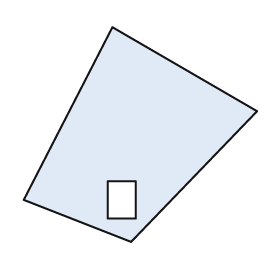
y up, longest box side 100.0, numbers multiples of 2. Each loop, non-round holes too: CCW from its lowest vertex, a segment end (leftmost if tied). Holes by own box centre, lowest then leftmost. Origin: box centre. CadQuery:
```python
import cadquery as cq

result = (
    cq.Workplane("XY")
    .moveTo(-4.0, -46.0)
    .lineTo(50.0, 10.0)
    .lineTo(-12.0, 46.0)
    .lineTo(-50.0, -28.0)
    .close()
    .moveTo(-14.0, -36.0)
    .lineTo(-2.0, -36.0)
    .lineTo(-2.0, -20.0)
    .lineTo(-14.0, -20.0)
    .close()
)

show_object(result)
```